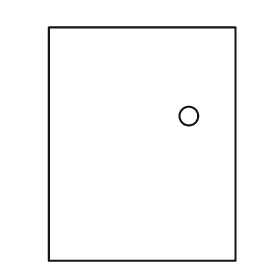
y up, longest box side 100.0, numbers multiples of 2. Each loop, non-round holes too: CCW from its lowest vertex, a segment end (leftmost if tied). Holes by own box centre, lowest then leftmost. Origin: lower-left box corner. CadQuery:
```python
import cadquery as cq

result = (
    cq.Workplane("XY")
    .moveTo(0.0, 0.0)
    .lineTo(80.0, 0.0)
    .lineTo(80.0, 100.0)
    .lineTo(0.0, 100.0)
    .close()
    .moveTo(60.0, 62.0)
    .circle(4.0)
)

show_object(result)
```